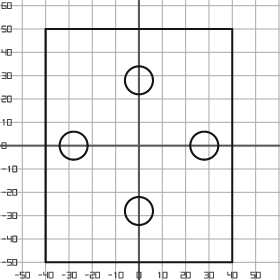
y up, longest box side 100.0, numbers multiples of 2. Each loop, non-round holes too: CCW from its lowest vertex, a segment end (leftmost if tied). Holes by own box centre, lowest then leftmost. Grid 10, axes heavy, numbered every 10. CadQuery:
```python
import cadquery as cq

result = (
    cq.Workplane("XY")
    .moveTo(-40.0, -50.0)
    .lineTo(40.0, -50.0)
    .lineTo(40.0, 50.0)
    .lineTo(-40.0, 50.0)
    .close()
    .moveTo(0.0, -28.0)
    .circle(6.0)
    .moveTo(-28.0, 0.0)
    .circle(6.0)
    .moveTo(28.0, 0.0)
    .circle(6.0)
    .moveTo(0.0, 28.0)
    .circle(6.0)
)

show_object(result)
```